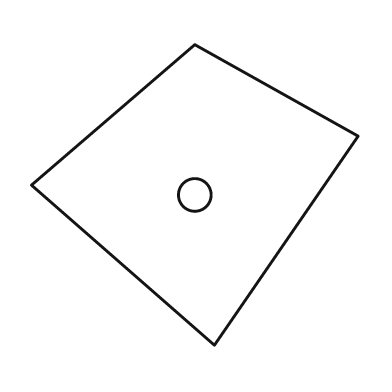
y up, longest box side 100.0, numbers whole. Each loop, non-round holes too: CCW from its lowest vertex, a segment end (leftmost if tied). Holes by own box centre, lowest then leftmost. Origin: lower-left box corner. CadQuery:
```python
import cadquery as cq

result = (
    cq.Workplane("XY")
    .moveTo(56.0, 0.0)
    .lineTo(100.0, 64.0)
    .lineTo(50.0, 92.0)
    .lineTo(0.0, 49.0)
    .close()
    .moveTo(50.0, 46.0)
    .circle(5.0)
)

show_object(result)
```